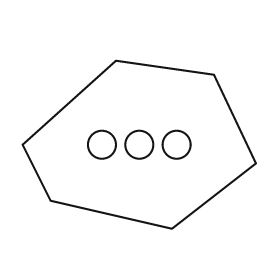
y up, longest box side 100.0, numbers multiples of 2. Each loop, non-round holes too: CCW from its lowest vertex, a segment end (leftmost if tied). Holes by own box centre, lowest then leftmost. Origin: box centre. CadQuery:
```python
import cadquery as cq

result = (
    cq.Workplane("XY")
    .moveTo(14.0, -36.0)
    .lineTo(50.0, -8.0)
    .lineTo(32.0, 30.0)
    .lineTo(-10.0, 36.0)
    .lineTo(-50.0, 0.0)
    .lineTo(-38.0, -24.0)
    .close()
    .moveTo(-16.0, 0.0)
    .circle(6.0)
    .moveTo(0.0, 0.0)
    .circle(6.0)
    .moveTo(16.0, 0.0)
    .circle(6.0)
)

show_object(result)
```